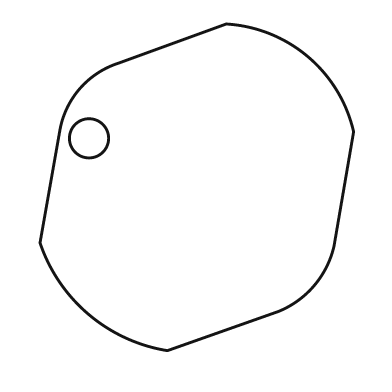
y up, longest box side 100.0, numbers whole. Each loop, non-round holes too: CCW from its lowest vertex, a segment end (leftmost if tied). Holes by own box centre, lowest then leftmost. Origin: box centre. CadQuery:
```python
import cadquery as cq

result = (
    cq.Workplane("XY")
    .moveTo(-9.0, -50.0)
    .lineTo(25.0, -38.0)
    .threePointArc((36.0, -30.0), (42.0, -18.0))
    .lineTo(48.0, 17.0)
    .threePointArc((34.0, 40.0), (9.0, 50.0))
    .lineTo(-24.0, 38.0)
    .threePointArc((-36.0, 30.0), (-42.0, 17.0))
    .lineTo(-48.0, -17.0)
    .threePointArc((-33.0, -39.0), (-9.0, -50.0))
    .close()
    .moveTo(-33.0, 15.0)
    .circle(6.0)
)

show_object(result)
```